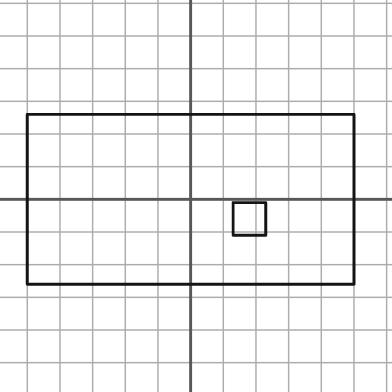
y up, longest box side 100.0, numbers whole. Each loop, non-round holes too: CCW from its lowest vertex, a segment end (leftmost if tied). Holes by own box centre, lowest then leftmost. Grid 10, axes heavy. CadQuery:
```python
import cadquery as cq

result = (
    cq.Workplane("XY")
    .moveTo(-50.0, -26.0)
    .lineTo(50.0, -26.0)
    .lineTo(50.0, 26.0)
    .lineTo(-50.0, 26.0)
    .close()
    .moveTo(13.0, -11.0)
    .lineTo(23.0, -11.0)
    .lineTo(23.0, -1.0)
    .lineTo(13.0, -1.0)
    .close()
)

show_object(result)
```